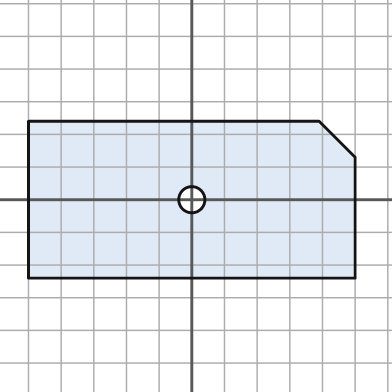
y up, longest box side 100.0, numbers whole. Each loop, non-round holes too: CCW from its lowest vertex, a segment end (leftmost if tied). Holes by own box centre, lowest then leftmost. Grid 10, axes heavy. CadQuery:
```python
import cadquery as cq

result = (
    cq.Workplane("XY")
    .moveTo(-50.0, -24.0)
    .lineTo(50.0, -24.0)
    .lineTo(50.0, 13.0)
    .lineTo(39.0, 24.0)
    .lineTo(-50.0, 24.0)
    .close()
    .moveTo(0.0, 0.0)
    .circle(4.0)
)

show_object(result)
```